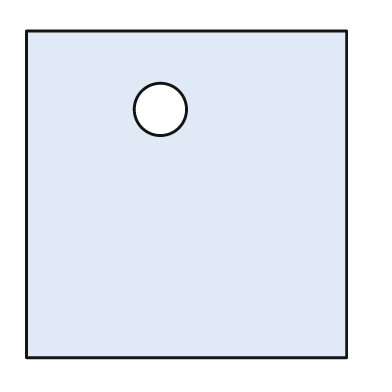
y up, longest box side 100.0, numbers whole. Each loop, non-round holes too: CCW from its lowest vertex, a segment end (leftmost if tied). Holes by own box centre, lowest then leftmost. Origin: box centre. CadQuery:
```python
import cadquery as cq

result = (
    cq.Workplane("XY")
    .moveTo(-49.0, -50.0)
    .lineTo(49.0, -50.0)
    .lineTo(49.0, 50.0)
    .lineTo(-49.0, 50.0)
    .close()
    .moveTo(-8.0, 26.0)
    .circle(8.0)
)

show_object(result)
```